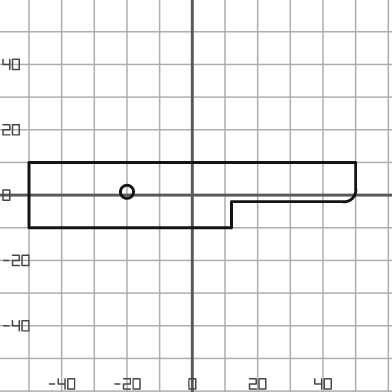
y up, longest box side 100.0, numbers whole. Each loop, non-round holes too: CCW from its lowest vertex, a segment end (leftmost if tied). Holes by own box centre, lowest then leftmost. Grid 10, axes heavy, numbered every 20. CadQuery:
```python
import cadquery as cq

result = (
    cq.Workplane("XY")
    .moveTo(-50.0, -10.0)
    .lineTo(12.0, -10.0)
    .lineTo(12.0, -2.0)
    .lineTo(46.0, -2.0)
    .threePointArc((49.0, -1.0), (50.0, 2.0))
    .lineTo(50.0, 10.0)
    .lineTo(-50.0, 10.0)
    .close()
    .moveTo(-20.0, 1.0)
    .circle(2.0)
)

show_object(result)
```